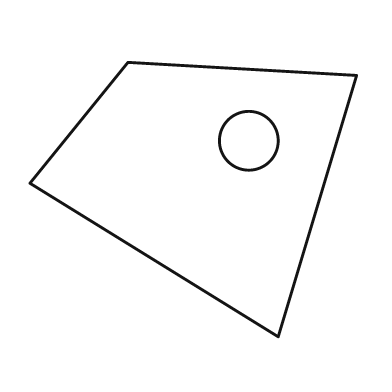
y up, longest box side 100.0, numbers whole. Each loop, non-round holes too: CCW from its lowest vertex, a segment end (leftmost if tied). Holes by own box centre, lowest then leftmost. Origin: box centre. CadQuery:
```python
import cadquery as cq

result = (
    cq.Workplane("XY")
    .moveTo(26.0, -42.0)
    .lineTo(50.0, 38.0)
    .lineTo(-20.0, 42.0)
    .lineTo(-50.0, 5.0)
    .close()
    .moveTo(17.0, 18.0)
    .circle(9.0)
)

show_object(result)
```